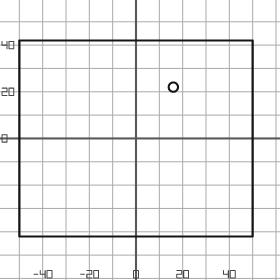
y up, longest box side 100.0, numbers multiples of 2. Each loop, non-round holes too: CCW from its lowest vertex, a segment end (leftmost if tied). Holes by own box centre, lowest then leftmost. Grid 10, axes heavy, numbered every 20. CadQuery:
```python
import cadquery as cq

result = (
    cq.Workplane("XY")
    .moveTo(-50.0, -42.0)
    .lineTo(50.0, -42.0)
    .lineTo(50.0, 42.0)
    .lineTo(-50.0, 42.0)
    .close()
    .moveTo(16.0, 22.0)
    .circle(2.0)
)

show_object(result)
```